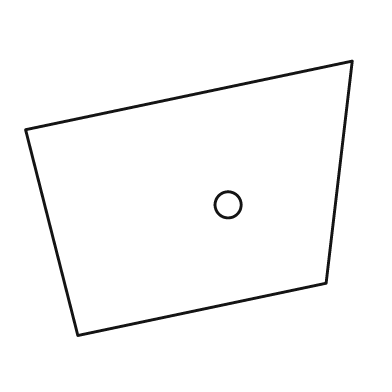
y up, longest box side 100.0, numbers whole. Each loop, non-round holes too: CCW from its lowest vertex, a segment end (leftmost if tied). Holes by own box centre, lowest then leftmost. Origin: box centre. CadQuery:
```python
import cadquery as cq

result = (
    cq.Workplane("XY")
    .moveTo(-34.0, -42.0)
    .lineTo(42.0, -26.0)
    .lineTo(50.0, 42.0)
    .lineTo(-50.0, 21.0)
    .close()
    .moveTo(12.0, -2.0)
    .circle(4.0)
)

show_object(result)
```